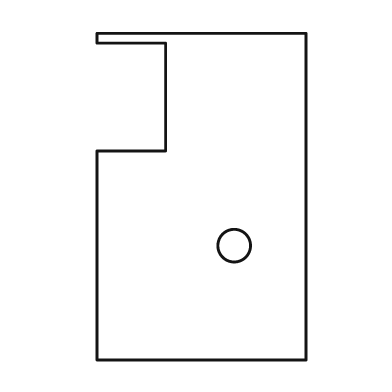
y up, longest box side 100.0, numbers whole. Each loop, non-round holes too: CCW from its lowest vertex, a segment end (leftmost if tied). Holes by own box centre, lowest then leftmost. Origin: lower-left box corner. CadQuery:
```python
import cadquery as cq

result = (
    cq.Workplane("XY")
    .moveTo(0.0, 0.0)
    .lineTo(64.0, 0.0)
    .lineTo(64.0, 100.0)
    .lineTo(0.0, 100.0)
    .lineTo(0.0, 97.0)
    .lineTo(21.0, 97.0)
    .lineTo(21.0, 64.0)
    .lineTo(0.0, 64.0)
    .close()
    .moveTo(42.0, 35.0)
    .circle(5.0)
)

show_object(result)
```